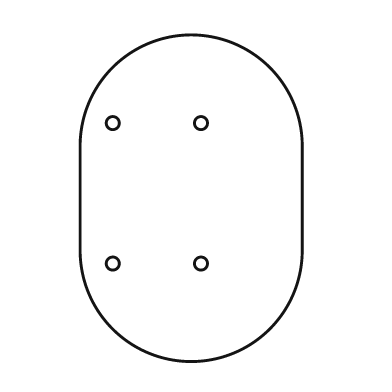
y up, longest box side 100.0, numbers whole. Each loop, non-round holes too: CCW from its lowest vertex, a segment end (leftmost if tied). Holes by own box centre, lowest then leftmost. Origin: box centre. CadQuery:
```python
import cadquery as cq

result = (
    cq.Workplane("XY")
    .moveTo(-34.0, -16.0)
    .threePointArc((0.0, -50.0), (34.0, -16.0))
    .lineTo(34.0, 16.0)
    .threePointArc((0.0, 50.0), (-34.0, 16.0))
    .close()
    .moveTo(-24.0, -20.0)
    .circle(2.0)
    .moveTo(3.0, -20.0)
    .circle(2.0)
    .moveTo(-24.0, 23.0)
    .circle(2.0)
    .moveTo(3.0, 23.0)
    .circle(2.0)
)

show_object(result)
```